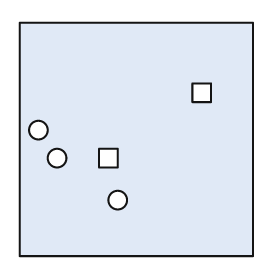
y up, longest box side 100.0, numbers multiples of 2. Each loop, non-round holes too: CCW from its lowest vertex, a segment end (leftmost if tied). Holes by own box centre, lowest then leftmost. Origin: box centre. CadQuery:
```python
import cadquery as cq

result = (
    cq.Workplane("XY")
    .moveTo(-50.0, -50.0)
    .lineTo(50.0, -50.0)
    .lineTo(50.0, 50.0)
    .lineTo(-50.0, 50.0)
    .close()
    .moveTo(-8.0, -26.0)
    .circle(4.0)
    .moveTo(-34.0, -8.0)
    .circle(4.0)
    .moveTo(-16.0, -12.0)
    .lineTo(-8.0, -12.0)
    .lineTo(-8.0, -4.0)
    .lineTo(-16.0, -4.0)
    .close()
    .moveTo(-42.0, 4.0)
    .circle(4.0)
    .moveTo(24.0, 16.0)
    .lineTo(32.0, 16.0)
    .lineTo(32.0, 24.0)
    .lineTo(24.0, 24.0)
    .close()
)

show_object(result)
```